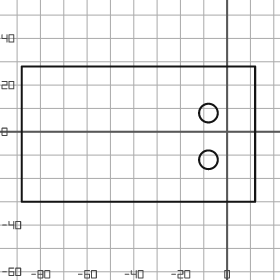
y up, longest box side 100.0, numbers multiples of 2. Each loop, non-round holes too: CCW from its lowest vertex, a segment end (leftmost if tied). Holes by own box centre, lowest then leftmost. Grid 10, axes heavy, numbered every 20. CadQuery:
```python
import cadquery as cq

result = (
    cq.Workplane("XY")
    .moveTo(-88.0, -30.0)
    .lineTo(12.0, -30.0)
    .lineTo(12.0, 28.0)
    .lineTo(-88.0, 28.0)
    .close()
    .moveTo(-8.0, -12.0)
    .circle(4.0)
    .moveTo(-8.0, 8.0)
    .circle(4.0)
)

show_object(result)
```